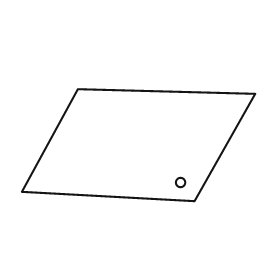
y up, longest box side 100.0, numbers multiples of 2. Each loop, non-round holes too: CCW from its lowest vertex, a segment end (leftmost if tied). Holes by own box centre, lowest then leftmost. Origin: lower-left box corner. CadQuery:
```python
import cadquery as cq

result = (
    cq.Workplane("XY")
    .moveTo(74.0, 0.0)
    .lineTo(100.0, 46.0)
    .lineTo(24.0, 48.0)
    .lineTo(0.0, 4.0)
    .close()
    .moveTo(68.0, 8.0)
    .circle(2.0)
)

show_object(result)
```